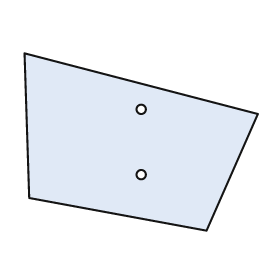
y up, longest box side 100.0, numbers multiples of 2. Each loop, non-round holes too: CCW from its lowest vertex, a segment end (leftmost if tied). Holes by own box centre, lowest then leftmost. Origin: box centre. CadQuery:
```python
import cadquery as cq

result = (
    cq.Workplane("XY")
    .moveTo(28.0, -38.0)
    .lineTo(50.0, 12.0)
    .lineTo(-50.0, 38.0)
    .lineTo(-48.0, -24.0)
    .close()
    .moveTo(0.0, -14.0)
    .circle(2.0)
    .moveTo(0.0, 14.0)
    .circle(2.0)
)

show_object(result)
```